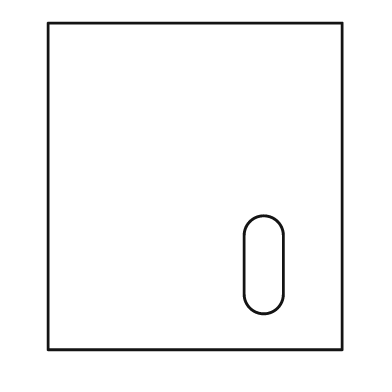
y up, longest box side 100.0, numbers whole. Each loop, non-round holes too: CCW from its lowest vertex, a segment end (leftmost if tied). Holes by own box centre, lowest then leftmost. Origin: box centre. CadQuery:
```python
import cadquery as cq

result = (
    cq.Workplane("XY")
    .moveTo(-45.0, -50.0)
    .lineTo(45.0, -50.0)
    .lineTo(45.0, 50.0)
    .lineTo(-45.0, 50.0)
    .close()
    .moveTo(15.0, -33.0)
    .threePointArc((21.0, -39.0), (27.0, -33.0))
    .lineTo(27.0, -15.0)
    .threePointArc((21.0, -9.0), (15.0, -15.0))
    .close()
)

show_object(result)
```